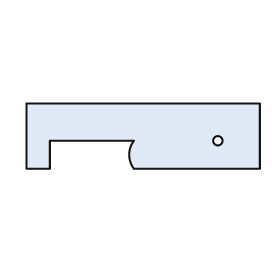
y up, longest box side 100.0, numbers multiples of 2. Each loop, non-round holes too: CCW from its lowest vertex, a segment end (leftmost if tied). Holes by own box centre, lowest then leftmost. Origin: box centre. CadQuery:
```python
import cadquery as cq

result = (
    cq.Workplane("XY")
    .moveTo(-50.0, -14.0)
    .lineTo(-40.0, -14.0)
    .lineTo(-40.0, -2.0)
    .lineTo(-4.0, -2.0)
    .threePointArc((-6.0, -8.0), (-4.0, -14.0))
    .lineTo(50.0, -14.0)
    .lineTo(50.0, 14.0)
    .lineTo(-50.0, 14.0)
    .close()
    .moveTo(32.0, -2.0)
    .circle(2.0)
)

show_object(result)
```